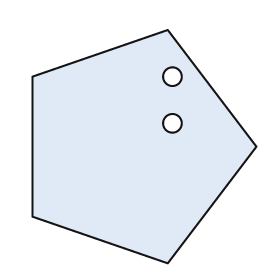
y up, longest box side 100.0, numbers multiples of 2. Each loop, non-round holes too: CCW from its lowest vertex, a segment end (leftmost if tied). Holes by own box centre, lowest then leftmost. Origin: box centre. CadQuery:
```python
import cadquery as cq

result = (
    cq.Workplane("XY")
    .moveTo(10.0, -50.0)
    .lineTo(48.0, 0.0)
    .lineTo(10.0, 50.0)
    .lineTo(-48.0, 30.0)
    .lineTo(-48.0, -30.0)
    .close()
    .moveTo(12.0, 10.0)
    .circle(4.0)
    .moveTo(12.0, 30.0)
    .circle(4.0)
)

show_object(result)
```